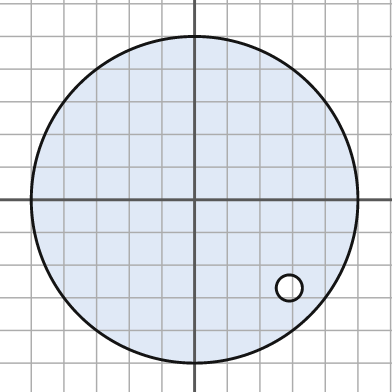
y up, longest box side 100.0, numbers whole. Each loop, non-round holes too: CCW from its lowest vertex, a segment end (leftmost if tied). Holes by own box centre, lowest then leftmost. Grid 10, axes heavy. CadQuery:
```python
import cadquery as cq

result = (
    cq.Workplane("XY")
    .moveTo(0.0, 0.0)
    .circle(50.0)
    .moveTo(29.0, -27.0)
    .circle(4.0)
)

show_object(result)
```